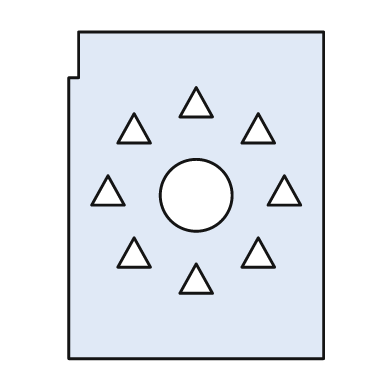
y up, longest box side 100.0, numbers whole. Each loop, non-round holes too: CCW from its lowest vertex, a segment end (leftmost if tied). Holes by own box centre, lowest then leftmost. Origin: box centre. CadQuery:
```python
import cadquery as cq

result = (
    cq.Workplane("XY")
    .moveTo(-39.0, -50.0)
    .lineTo(39.0, -50.0)
    .lineTo(39.0, 50.0)
    .lineTo(-36.0, 50.0)
    .lineTo(-36.0, 36.0)
    .lineTo(-39.0, 36.0)
    .close()
    .moveTo(-5.0, -30.0)
    .lineTo(5.0, -30.0)
    .lineTo(0.0, -21.0)
    .close()
    .moveTo(-24.0, -22.0)
    .lineTo(-14.0, -22.0)
    .lineTo(-19.0, -13.0)
    .close()
    .moveTo(14.0, -22.0)
    .lineTo(24.0, -22.0)
    .lineTo(19.0, -13.0)
    .close()
    .moveTo(0.0, 0.0)
    .circle(11.0)
    .moveTo(-32.0, -3.0)
    .lineTo(-22.0, -3.0)
    .lineTo(-27.0, 6.0)
    .close()
    .moveTo(22.0, -3.0)
    .lineTo(32.0, -3.0)
    .lineTo(27.0, 6.0)
    .close()
    .moveTo(-24.0, 16.0)
    .lineTo(-14.0, 16.0)
    .lineTo(-19.0, 25.0)
    .close()
    .moveTo(14.0, 16.0)
    .lineTo(24.0, 16.0)
    .lineTo(19.0, 25.0)
    .close()
    .moveTo(-5.0, 24.0)
    .lineTo(5.0, 24.0)
    .lineTo(0.0, 33.0)
    .close()
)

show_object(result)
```